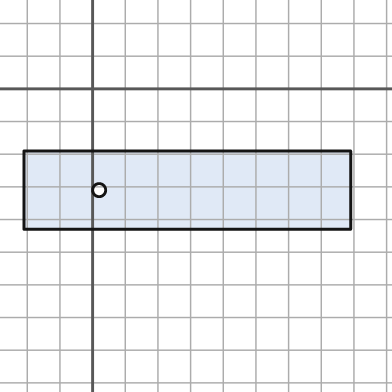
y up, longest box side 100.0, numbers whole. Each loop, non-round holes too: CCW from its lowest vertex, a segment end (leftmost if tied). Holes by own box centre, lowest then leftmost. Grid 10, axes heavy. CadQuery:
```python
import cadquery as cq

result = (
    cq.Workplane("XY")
    .moveTo(-21.0, -43.0)
    .lineTo(79.0, -43.0)
    .lineTo(79.0, -19.0)
    .lineTo(-21.0, -19.0)
    .close()
    .moveTo(2.0, -31.0)
    .circle(2.0)
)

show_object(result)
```